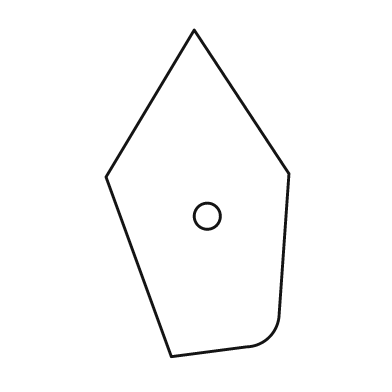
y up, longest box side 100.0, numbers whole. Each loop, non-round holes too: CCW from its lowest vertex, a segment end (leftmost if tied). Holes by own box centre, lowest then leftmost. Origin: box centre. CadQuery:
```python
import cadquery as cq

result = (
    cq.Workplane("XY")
    .moveTo(-8.0, -50.0)
    .lineTo(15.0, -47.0)
    .threePointArc((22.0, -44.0), (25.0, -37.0))
    .lineTo(28.0, 6.0)
    .lineTo(-1.0, 50.0)
    .lineTo(-28.0, 5.0)
    .close()
    .moveTo(3.0, -7.0)
    .circle(4.0)
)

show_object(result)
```